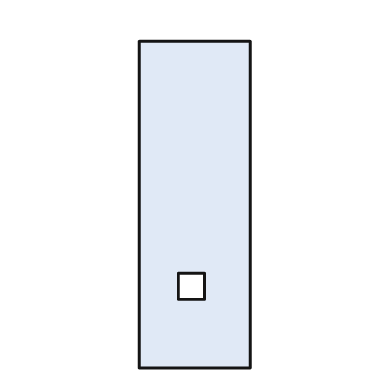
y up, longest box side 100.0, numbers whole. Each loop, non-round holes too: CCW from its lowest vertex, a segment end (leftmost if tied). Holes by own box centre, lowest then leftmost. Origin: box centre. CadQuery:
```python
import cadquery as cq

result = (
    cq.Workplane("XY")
    .moveTo(-17.0, -50.0)
    .lineTo(17.0, -50.0)
    .lineTo(17.0, 50.0)
    .lineTo(-17.0, 50.0)
    .close()
    .moveTo(-5.0, -29.0)
    .lineTo(3.0, -29.0)
    .lineTo(3.0, -21.0)
    .lineTo(-5.0, -21.0)
    .close()
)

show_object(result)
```